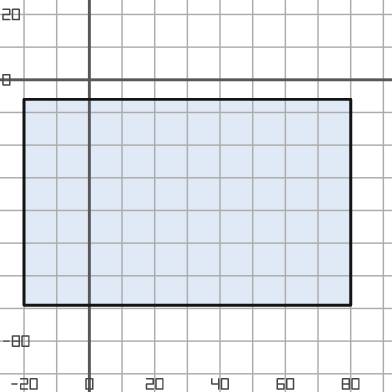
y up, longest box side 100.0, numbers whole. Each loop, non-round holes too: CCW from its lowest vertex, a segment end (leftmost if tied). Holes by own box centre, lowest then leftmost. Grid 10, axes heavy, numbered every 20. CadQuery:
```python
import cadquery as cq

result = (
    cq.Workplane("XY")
    .moveTo(-20.0, -69.0)
    .lineTo(80.0, -69.0)
    .lineTo(80.0, -6.0)
    .lineTo(-20.0, -6.0)
    .close()
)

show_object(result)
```